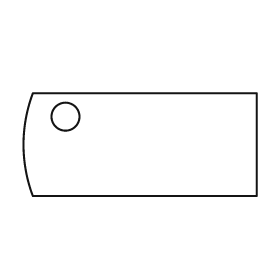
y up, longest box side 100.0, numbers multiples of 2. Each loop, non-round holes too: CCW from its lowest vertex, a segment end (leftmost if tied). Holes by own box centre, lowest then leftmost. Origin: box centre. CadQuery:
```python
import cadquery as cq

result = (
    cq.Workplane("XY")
    .moveTo(-46.0, -22.0)
    .lineTo(50.0, -22.0)
    .lineTo(50.0, 22.0)
    .lineTo(-46.0, 22.0)
    .threePointArc((-50.0, 0.0), (-46.0, -22.0))
    .close()
    .moveTo(-32.0, 12.0)
    .circle(6.0)
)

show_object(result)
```